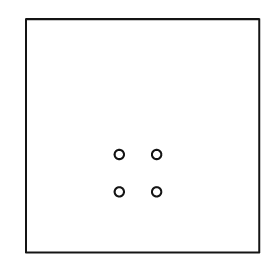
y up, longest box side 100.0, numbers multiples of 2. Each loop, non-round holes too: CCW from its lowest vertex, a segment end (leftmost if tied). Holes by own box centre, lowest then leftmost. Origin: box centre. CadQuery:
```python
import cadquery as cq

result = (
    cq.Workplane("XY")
    .moveTo(-50.0, -50.0)
    .lineTo(50.0, -50.0)
    .lineTo(50.0, 50.0)
    .lineTo(-50.0, 50.0)
    .close()
    .moveTo(-10.0, -24.0)
    .circle(2.0)
    .moveTo(6.0, -24.0)
    .circle(2.0)
    .moveTo(-10.0, -8.0)
    .circle(2.0)
    .moveTo(6.0, -8.0)
    .circle(2.0)
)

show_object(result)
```